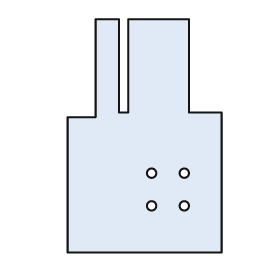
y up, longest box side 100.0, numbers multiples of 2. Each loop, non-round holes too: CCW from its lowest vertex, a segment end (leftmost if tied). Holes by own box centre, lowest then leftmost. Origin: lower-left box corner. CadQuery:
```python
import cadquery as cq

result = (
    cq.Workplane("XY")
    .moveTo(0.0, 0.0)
    .lineTo(66.0, 0.0)
    .lineTo(66.0, 60.0)
    .lineTo(52.0, 60.0)
    .lineTo(52.0, 100.0)
    .lineTo(26.0, 100.0)
    .lineTo(26.0, 60.0)
    .lineTo(22.0, 60.0)
    .lineTo(22.0, 100.0)
    .lineTo(12.0, 100.0)
    .lineTo(12.0, 58.0)
    .lineTo(0.0, 58.0)
    .close()
    .moveTo(36.0, 20.0)
    .circle(2.0)
    .moveTo(50.0, 20.0)
    .circle(2.0)
    .moveTo(36.0, 34.0)
    .circle(2.0)
    .moveTo(50.0, 34.0)
    .circle(2.0)
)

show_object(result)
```